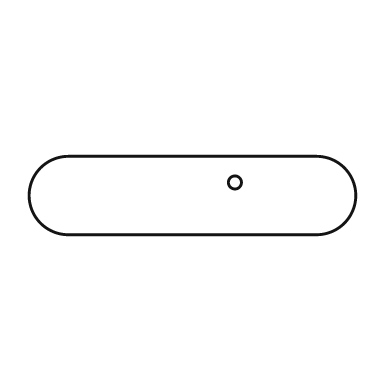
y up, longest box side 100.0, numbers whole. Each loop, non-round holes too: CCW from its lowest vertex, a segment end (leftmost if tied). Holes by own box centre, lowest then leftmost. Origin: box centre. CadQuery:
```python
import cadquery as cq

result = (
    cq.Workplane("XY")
    .moveTo(-38.0, -12.0)
    .lineTo(38.0, -12.0)
    .threePointArc((50.0, 0.0), (38.0, 12.0))
    .lineTo(-38.0, 12.0)
    .threePointArc((-50.0, 0.0), (-38.0, -12.0))
    .close()
    .moveTo(13.0, 4.0)
    .circle(2.0)
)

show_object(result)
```